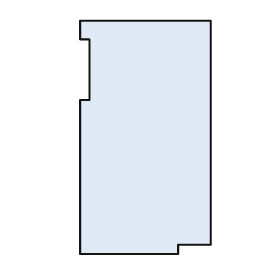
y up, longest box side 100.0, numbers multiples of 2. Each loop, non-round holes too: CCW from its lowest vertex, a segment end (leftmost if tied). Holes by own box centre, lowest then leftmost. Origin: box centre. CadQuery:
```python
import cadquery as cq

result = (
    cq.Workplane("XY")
    .moveTo(-28.0, -50.0)
    .lineTo(14.0, -50.0)
    .lineTo(14.0, -46.0)
    .lineTo(28.0, -46.0)
    .lineTo(28.0, 50.0)
    .lineTo(-28.0, 50.0)
    .lineTo(-28.0, 42.0)
    .lineTo(-24.0, 42.0)
    .lineTo(-24.0, 16.0)
    .lineTo(-28.0, 16.0)
    .close()
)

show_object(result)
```